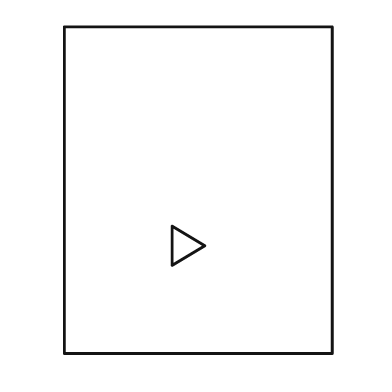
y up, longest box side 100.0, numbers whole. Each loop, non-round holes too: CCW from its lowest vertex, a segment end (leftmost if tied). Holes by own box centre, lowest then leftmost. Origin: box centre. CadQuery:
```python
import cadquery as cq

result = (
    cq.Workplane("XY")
    .moveTo(-41.0, -50.0)
    .lineTo(41.0, -50.0)
    .lineTo(41.0, 50.0)
    .lineTo(-41.0, 50.0)
    .close()
    .moveTo(-8.0, -23.0)
    .lineTo(2.0, -17.0)
    .lineTo(-8.0, -11.0)
    .close()
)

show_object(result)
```